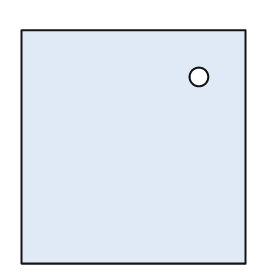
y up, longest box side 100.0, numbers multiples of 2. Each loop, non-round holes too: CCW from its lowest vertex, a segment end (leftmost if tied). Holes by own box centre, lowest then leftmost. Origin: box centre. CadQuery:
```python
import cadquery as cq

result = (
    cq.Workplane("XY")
    .moveTo(-48.0, -50.0)
    .lineTo(48.0, -50.0)
    .lineTo(48.0, 50.0)
    .lineTo(-48.0, 50.0)
    .close()
    .moveTo(28.0, 30.0)
    .circle(4.0)
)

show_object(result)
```